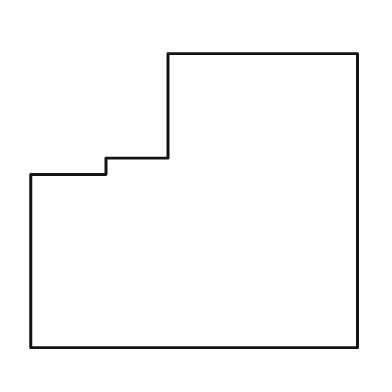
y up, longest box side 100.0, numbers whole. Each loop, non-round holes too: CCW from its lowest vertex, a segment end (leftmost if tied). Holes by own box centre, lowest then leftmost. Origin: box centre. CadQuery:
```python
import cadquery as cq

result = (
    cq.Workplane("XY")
    .moveTo(-50.0, -45.0)
    .lineTo(50.0, -45.0)
    .lineTo(50.0, 45.0)
    .lineTo(-8.0, 45.0)
    .lineTo(-8.0, 13.0)
    .lineTo(-27.0, 13.0)
    .lineTo(-27.0, 8.0)
    .lineTo(-50.0, 8.0)
    .close()
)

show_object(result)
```